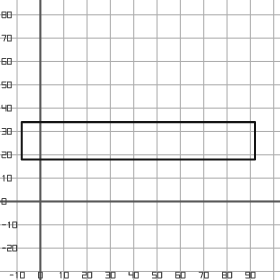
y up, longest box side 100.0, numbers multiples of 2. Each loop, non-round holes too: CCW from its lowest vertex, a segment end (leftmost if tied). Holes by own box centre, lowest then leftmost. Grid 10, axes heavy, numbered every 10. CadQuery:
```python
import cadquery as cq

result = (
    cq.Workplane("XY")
    .moveTo(-8.0, 18.0)
    .lineTo(92.0, 18.0)
    .lineTo(92.0, 34.0)
    .lineTo(-8.0, 34.0)
    .close()
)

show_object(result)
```